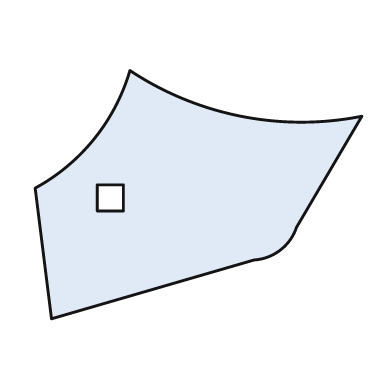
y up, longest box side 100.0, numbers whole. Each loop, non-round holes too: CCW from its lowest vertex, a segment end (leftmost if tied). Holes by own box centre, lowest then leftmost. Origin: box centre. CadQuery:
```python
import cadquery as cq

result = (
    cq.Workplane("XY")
    .moveTo(-45.0, -38.0)
    .lineTo(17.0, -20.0)
    .threePointArc((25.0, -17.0), (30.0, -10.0))
    .lineTo(50.0, 24.0)
    .threePointArc((13.0, 24.0), (-21.0, 38.0))
    .threePointArc((-32.0, 17.0), (-50.0, 2.0))
    .close()
    .moveTo(-31.0, -5.0)
    .lineTo(-23.0, -5.0)
    .lineTo(-23.0, 3.0)
    .lineTo(-31.0, 3.0)
    .close()
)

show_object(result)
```